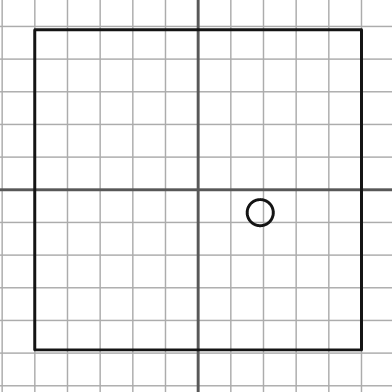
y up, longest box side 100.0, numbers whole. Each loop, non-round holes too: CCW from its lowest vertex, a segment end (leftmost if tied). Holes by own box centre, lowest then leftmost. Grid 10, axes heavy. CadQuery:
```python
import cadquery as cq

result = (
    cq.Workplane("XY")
    .moveTo(-50.0, -49.0)
    .lineTo(50.0, -49.0)
    .lineTo(50.0, 49.0)
    .lineTo(-50.0, 49.0)
    .close()
    .moveTo(19.0, -7.0)
    .circle(4.0)
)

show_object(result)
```